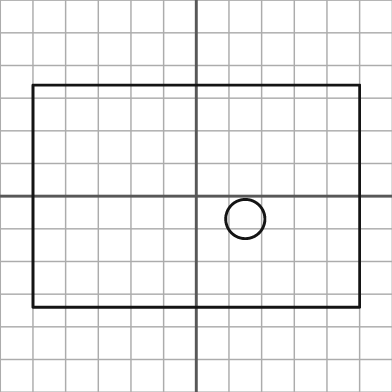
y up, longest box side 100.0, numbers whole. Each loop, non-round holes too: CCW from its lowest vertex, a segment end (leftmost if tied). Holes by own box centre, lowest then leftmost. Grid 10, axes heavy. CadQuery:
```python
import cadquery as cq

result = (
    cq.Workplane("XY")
    .moveTo(-50.0, -34.0)
    .lineTo(50.0, -34.0)
    .lineTo(50.0, 34.0)
    .lineTo(-50.0, 34.0)
    .close()
    .moveTo(15.0, -7.0)
    .circle(6.0)
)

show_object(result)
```